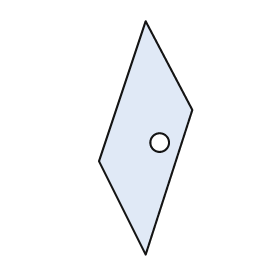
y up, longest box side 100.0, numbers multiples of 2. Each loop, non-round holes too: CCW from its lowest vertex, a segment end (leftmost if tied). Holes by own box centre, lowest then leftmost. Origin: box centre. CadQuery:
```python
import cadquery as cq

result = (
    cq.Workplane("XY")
    .moveTo(0.0, -50.0)
    .lineTo(20.0, 12.0)
    .lineTo(0.0, 50.0)
    .lineTo(-20.0, -10.0)
    .close()
    .moveTo(6.0, -2.0)
    .circle(4.0)
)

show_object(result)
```